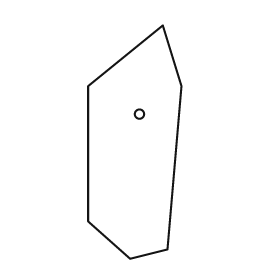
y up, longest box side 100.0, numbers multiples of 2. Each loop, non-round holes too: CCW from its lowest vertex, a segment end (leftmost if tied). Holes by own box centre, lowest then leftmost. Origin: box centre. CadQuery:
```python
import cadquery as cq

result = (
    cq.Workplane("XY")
    .moveTo(-2.0, -50.0)
    .lineTo(14.0, -46.0)
    .lineTo(20.0, 24.0)
    .lineTo(12.0, 50.0)
    .lineTo(-20.0, 24.0)
    .lineTo(-20.0, -34.0)
    .close()
    .moveTo(2.0, 12.0)
    .circle(2.0)
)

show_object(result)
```